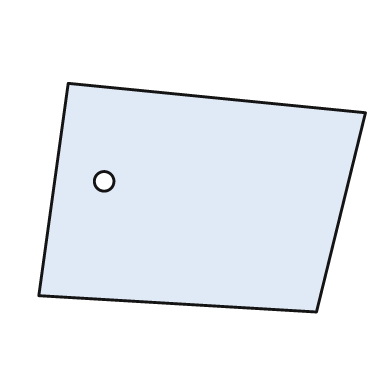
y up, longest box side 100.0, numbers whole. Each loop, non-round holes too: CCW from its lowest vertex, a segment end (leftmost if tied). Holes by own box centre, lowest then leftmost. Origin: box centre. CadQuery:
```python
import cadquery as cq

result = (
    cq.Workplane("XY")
    .moveTo(35.0, -35.0)
    .lineTo(50.0, 26.0)
    .lineTo(-41.0, 35.0)
    .lineTo(-50.0, -30.0)
    .close()
    .moveTo(-30.0, 5.0)
    .circle(3.0)
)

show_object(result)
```